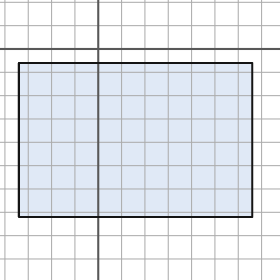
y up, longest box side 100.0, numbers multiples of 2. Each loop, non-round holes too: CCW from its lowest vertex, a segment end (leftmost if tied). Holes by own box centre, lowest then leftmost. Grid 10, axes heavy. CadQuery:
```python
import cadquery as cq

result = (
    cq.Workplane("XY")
    .moveTo(-34.0, -72.0)
    .lineTo(66.0, -72.0)
    .lineTo(66.0, -6.0)
    .lineTo(-34.0, -6.0)
    .close()
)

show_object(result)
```